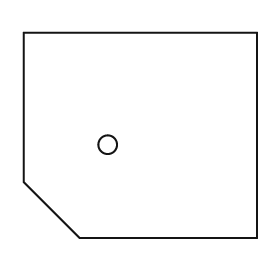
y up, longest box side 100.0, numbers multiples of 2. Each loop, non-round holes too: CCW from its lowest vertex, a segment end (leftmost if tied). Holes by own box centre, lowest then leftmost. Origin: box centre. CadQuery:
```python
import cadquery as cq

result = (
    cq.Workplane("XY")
    .moveTo(-26.0, -44.0)
    .lineTo(50.0, -44.0)
    .lineTo(50.0, 44.0)
    .lineTo(-50.0, 44.0)
    .lineTo(-50.0, -20.0)
    .close()
    .moveTo(-14.0, -4.0)
    .circle(4.0)
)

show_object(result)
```